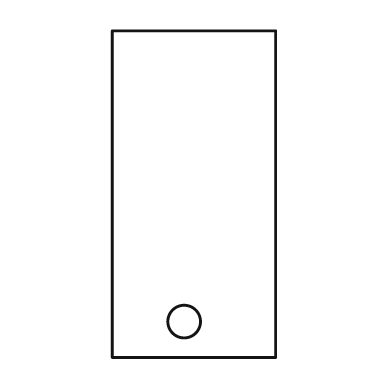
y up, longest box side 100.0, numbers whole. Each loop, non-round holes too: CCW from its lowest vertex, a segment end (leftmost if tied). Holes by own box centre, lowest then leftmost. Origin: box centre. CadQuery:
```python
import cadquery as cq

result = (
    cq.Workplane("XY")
    .moveTo(-25.0, -50.0)
    .lineTo(25.0, -50.0)
    .lineTo(25.0, 50.0)
    .lineTo(-25.0, 50.0)
    .close()
    .moveTo(-3.0, -39.0)
    .circle(5.0)
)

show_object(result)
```